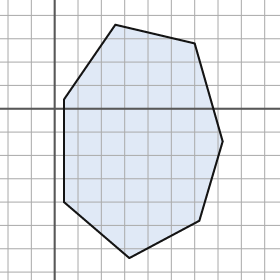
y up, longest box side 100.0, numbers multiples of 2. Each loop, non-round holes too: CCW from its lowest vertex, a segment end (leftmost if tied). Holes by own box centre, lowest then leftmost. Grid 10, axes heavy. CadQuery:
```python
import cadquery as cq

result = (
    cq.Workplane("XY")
    .moveTo(32.0, -64.0)
    .lineTo(62.0, -48.0)
    .lineTo(72.0, -14.0)
    .lineTo(60.0, 28.0)
    .lineTo(26.0, 36.0)
    .lineTo(4.0, 4.0)
    .lineTo(4.0, -40.0)
    .close()
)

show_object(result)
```